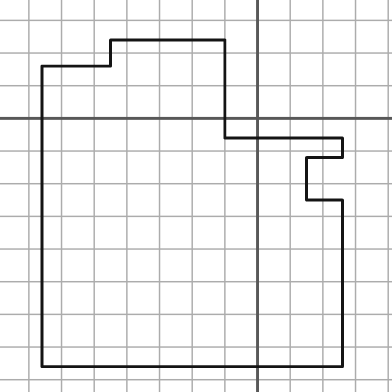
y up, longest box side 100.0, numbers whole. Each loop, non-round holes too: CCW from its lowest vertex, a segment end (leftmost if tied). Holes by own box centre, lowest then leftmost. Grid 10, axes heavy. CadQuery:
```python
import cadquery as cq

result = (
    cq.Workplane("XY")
    .moveTo(-66.0, -76.0)
    .lineTo(26.0, -76.0)
    .lineTo(26.0, -25.0)
    .lineTo(15.0, -25.0)
    .lineTo(15.0, -12.0)
    .lineTo(26.0, -12.0)
    .lineTo(26.0, -6.0)
    .lineTo(-10.0, -6.0)
    .lineTo(-10.0, 24.0)
    .lineTo(-45.0, 24.0)
    .lineTo(-45.0, 16.0)
    .lineTo(-66.0, 16.0)
    .close()
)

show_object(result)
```